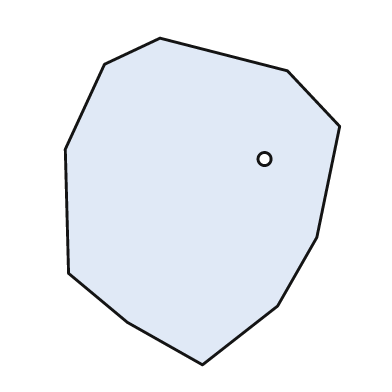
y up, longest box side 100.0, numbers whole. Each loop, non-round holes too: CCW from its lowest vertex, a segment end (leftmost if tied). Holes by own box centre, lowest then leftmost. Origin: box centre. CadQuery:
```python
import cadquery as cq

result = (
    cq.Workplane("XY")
    .moveTo(0.0, -50.0)
    .lineTo(23.0, -32.0)
    .lineTo(35.0, -11.0)
    .lineTo(42.0, 23.0)
    .lineTo(26.0, 40.0)
    .lineTo(-13.0, 50.0)
    .lineTo(-30.0, 42.0)
    .lineTo(-42.0, 16.0)
    .lineTo(-41.0, -22.0)
    .lineTo(-23.0, -37.0)
    .close()
    .moveTo(19.0, 13.0)
    .circle(2.0)
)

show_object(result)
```